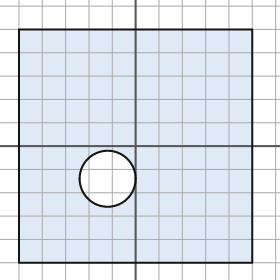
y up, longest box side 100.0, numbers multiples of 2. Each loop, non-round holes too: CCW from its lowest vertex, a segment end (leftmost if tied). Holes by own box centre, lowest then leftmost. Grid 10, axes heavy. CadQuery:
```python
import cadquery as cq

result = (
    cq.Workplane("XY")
    .moveTo(-50.0, -50.0)
    .lineTo(50.0, -50.0)
    .lineTo(50.0, 50.0)
    .lineTo(-50.0, 50.0)
    .close()
    .moveTo(-12.0, -14.0)
    .circle(12.0)
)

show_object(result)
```